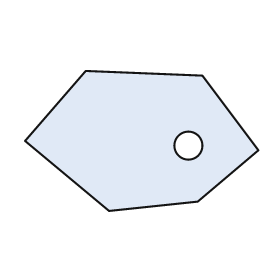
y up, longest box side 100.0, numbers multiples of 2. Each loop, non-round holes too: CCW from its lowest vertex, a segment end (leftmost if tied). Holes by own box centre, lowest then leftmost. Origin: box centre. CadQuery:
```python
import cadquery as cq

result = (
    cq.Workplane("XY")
    .moveTo(-14.0, -30.0)
    .lineTo(24.0, -26.0)
    .lineTo(50.0, -4.0)
    .lineTo(26.0, 28.0)
    .lineTo(-24.0, 30.0)
    .lineTo(-50.0, 0.0)
    .close()
    .moveTo(20.0, -2.0)
    .circle(6.0)
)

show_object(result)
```